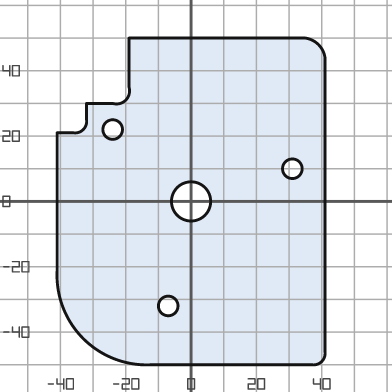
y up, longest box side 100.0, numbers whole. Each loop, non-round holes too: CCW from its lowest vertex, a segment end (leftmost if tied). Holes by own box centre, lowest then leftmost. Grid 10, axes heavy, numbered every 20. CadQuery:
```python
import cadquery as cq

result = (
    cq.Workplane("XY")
    .moveTo(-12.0, -50.0)
    .lineTo(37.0, -50.0)
    .threePointArc((40.0, -49.0), (41.0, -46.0))
    .lineTo(41.0, 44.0)
    .threePointArc((39.0, 48.0), (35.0, 50.0))
    .lineTo(-19.0, 50.0)
    .lineTo(-19.0, 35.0)
    .threePointArc((-20.0, 31.0), (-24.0, 30.0))
    .lineTo(-32.0, 30.0)
    .lineTo(-32.0, 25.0)
    .threePointArc((-33.0, 22.0), (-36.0, 21.0))
    .lineTo(-41.0, 21.0)
    .lineTo(-41.0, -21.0)
    .threePointArc((-33.0, -42.0), (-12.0, -50.0))
    .close()
    .moveTo(-7.0, -32.0)
    .circle(3.0)
    .moveTo(0.0, 0.0)
    .circle(6.0)
    .moveTo(31.0, 10.0)
    .circle(3.0)
    .moveTo(-24.0, 22.0)
    .circle(3.0)
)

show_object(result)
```